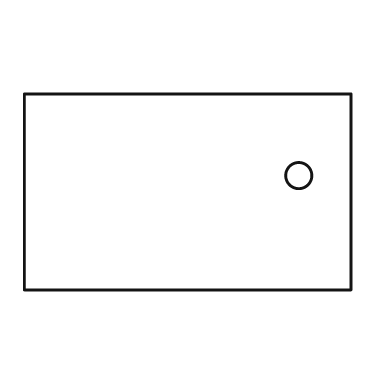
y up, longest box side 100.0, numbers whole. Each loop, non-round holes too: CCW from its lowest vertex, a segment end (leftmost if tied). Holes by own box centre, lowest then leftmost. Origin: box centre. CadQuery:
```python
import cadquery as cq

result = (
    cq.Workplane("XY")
    .moveTo(-50.0, -30.0)
    .lineTo(50.0, -30.0)
    .lineTo(50.0, 30.0)
    .lineTo(-50.0, 30.0)
    .close()
    .moveTo(34.0, 5.0)
    .circle(4.0)
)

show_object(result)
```